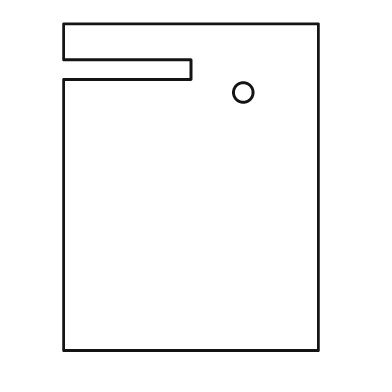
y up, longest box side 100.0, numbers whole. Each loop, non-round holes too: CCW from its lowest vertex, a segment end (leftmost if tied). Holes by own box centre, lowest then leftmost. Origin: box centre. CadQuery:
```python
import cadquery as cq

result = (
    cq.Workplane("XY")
    .moveTo(-39.0, -50.0)
    .lineTo(39.0, -50.0)
    .lineTo(39.0, 50.0)
    .lineTo(-39.0, 50.0)
    .lineTo(-39.0, 39.0)
    .lineTo(0.0, 39.0)
    .lineTo(0.0, 33.0)
    .lineTo(-39.0, 33.0)
    .close()
    .moveTo(16.0, 29.0)
    .circle(3.0)
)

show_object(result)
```